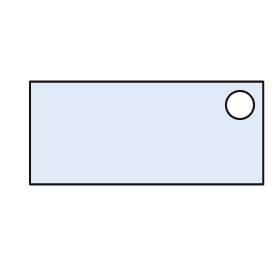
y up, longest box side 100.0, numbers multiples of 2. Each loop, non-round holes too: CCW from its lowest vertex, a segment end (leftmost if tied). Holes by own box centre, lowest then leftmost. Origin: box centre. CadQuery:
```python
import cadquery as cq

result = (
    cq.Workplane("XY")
    .moveTo(-50.0, -22.0)
    .lineTo(50.0, -22.0)
    .lineTo(50.0, 22.0)
    .lineTo(-50.0, 22.0)
    .close()
    .moveTo(40.0, 12.0)
    .circle(6.0)
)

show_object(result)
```